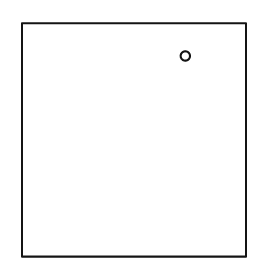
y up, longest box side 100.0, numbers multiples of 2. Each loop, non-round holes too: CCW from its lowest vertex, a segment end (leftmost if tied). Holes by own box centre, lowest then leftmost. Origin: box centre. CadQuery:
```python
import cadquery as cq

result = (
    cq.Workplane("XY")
    .moveTo(-48.0, -50.0)
    .lineTo(48.0, -50.0)
    .lineTo(48.0, 50.0)
    .lineTo(-48.0, 50.0)
    .close()
    .moveTo(22.0, 36.0)
    .circle(2.0)
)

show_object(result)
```